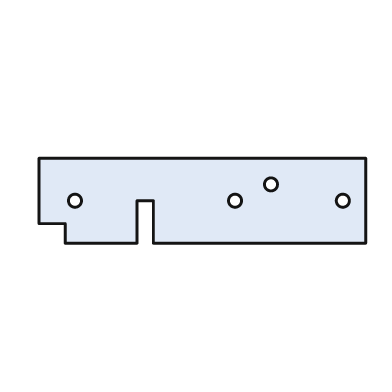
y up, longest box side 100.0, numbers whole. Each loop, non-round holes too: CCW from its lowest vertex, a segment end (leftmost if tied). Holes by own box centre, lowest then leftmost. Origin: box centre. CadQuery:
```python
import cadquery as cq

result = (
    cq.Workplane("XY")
    .moveTo(-42.0, -13.0)
    .lineTo(-20.0, -13.0)
    .lineTo(-20.0, 0.0)
    .lineTo(-15.0, 0.0)
    .lineTo(-15.0, -13.0)
    .lineTo(50.0, -13.0)
    .lineTo(50.0, 13.0)
    .lineTo(-50.0, 13.0)
    .lineTo(-50.0, -7.0)
    .lineTo(-42.0, -7.0)
    .close()
    .moveTo(-39.0, 0.0)
    .circle(2.0)
    .moveTo(10.0, 0.0)
    .circle(2.0)
    .moveTo(43.0, 0.0)
    .circle(2.0)
    .moveTo(21.0, 5.0)
    .circle(2.0)
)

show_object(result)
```